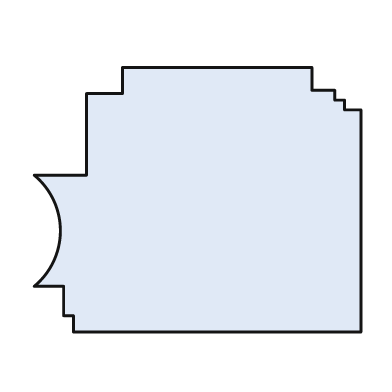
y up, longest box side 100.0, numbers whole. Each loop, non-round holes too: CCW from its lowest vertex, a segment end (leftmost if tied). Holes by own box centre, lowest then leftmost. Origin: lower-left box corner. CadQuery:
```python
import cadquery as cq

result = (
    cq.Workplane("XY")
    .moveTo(12.0, 0.0)
    .lineTo(100.0, 0.0)
    .lineTo(100.0, 68.0)
    .lineTo(95.0, 68.0)
    .lineTo(95.0, 71.0)
    .lineTo(92.0, 71.0)
    .lineTo(92.0, 74.0)
    .lineTo(85.0, 74.0)
    .lineTo(85.0, 81.0)
    .lineTo(27.0, 81.0)
    .lineTo(27.0, 73.0)
    .lineTo(16.0, 73.0)
    .lineTo(16.0, 48.0)
    .lineTo(0.0, 48.0)
    .threePointArc((8.0, 31.0), (0.0, 14.0))
    .lineTo(9.0, 14.0)
    .lineTo(9.0, 5.0)
    .lineTo(12.0, 5.0)
    .close()
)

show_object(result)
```